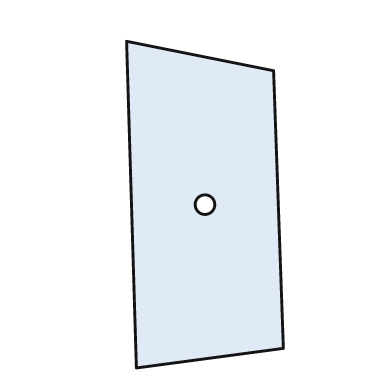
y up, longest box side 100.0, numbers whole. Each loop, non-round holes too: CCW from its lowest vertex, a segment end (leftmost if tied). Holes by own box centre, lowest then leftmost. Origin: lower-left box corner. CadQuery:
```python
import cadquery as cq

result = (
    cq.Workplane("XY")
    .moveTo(3.0, 0.0)
    .lineTo(48.0, 6.0)
    .lineTo(45.0, 91.0)
    .lineTo(0.0, 100.0)
    .close()
    .moveTo(24.0, 50.0)
    .circle(3.0)
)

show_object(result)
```